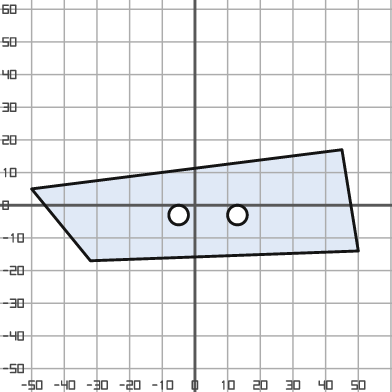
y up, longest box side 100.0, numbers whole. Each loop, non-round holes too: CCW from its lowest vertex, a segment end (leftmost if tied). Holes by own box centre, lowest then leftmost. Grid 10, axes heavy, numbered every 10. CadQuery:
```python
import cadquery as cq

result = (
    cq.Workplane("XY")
    .moveTo(-32.0, -17.0)
    .lineTo(50.0, -14.0)
    .lineTo(45.0, 17.0)
    .lineTo(-50.0, 5.0)
    .close()
    .moveTo(-5.0, -3.0)
    .circle(3.0)
    .moveTo(13.0, -3.0)
    .circle(3.0)
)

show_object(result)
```